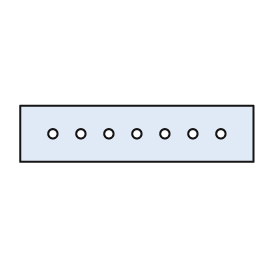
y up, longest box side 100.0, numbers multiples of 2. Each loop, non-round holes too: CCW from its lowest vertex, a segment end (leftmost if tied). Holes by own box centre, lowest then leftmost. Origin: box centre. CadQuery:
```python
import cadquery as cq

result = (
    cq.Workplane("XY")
    .moveTo(-50.0, -12.0)
    .lineTo(50.0, -12.0)
    .lineTo(50.0, 12.0)
    .lineTo(-50.0, 12.0)
    .close()
    .moveTo(-36.0, 0.0)
    .circle(2.0)
    .moveTo(-24.0, 0.0)
    .circle(2.0)
    .moveTo(-12.0, 0.0)
    .circle(2.0)
    .moveTo(0.0, 0.0)
    .circle(2.0)
    .moveTo(12.0, 0.0)
    .circle(2.0)
    .moveTo(24.0, 0.0)
    .circle(2.0)
    .moveTo(36.0, 0.0)
    .circle(2.0)
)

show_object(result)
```